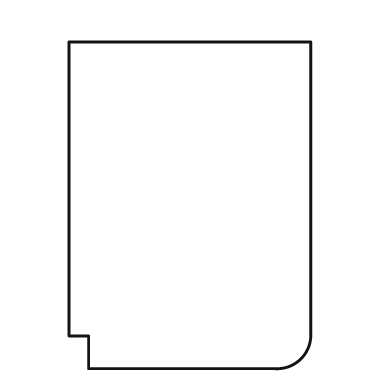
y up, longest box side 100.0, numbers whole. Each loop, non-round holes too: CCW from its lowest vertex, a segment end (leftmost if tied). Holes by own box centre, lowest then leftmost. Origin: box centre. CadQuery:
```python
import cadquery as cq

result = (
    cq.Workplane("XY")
    .moveTo(-31.0, -50.0)
    .lineTo(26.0, -50.0)
    .threePointArc((34.0, -47.0), (37.0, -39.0))
    .lineTo(37.0, 50.0)
    .lineTo(-37.0, 50.0)
    .lineTo(-37.0, -40.0)
    .lineTo(-31.0, -40.0)
    .close()
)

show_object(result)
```